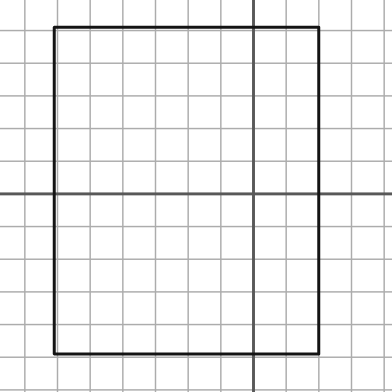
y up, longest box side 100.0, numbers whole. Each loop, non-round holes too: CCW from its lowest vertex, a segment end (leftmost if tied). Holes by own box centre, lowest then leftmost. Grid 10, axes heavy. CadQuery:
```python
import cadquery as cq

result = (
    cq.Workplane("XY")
    .moveTo(-61.0, -49.0)
    .lineTo(20.0, -49.0)
    .lineTo(20.0, 51.0)
    .lineTo(-61.0, 51.0)
    .close()
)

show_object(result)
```